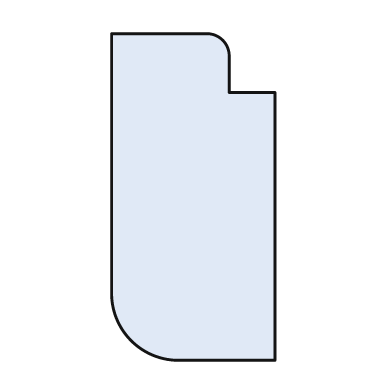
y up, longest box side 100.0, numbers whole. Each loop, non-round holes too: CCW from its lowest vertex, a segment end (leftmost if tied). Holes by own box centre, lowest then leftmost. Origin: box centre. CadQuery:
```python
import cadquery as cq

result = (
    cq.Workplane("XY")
    .moveTo(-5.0, -50.0)
    .lineTo(25.0, -50.0)
    .lineTo(25.0, 32.0)
    .lineTo(11.0, 32.0)
    .lineTo(11.0, 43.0)
    .threePointArc((9.0, 48.0), (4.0, 50.0))
    .lineTo(-25.0, 50.0)
    .lineTo(-25.0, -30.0)
    .threePointArc((-19.0, -44.0), (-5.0, -50.0))
    .close()
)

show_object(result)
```